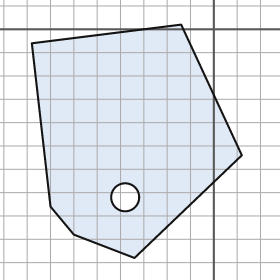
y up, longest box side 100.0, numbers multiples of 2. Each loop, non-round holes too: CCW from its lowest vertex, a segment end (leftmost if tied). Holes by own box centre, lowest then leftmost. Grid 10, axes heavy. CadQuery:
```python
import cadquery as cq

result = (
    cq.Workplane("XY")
    .moveTo(-34.0, -98.0)
    .lineTo(12.0, -54.0)
    .lineTo(-14.0, 2.0)
    .lineTo(-78.0, -6.0)
    .lineTo(-70.0, -76.0)
    .lineTo(-60.0, -88.0)
    .close()
    .moveTo(-38.0, -72.0)
    .circle(6.0)
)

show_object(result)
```